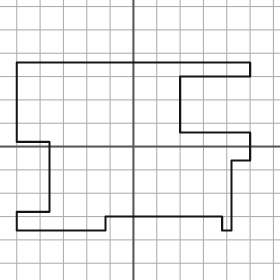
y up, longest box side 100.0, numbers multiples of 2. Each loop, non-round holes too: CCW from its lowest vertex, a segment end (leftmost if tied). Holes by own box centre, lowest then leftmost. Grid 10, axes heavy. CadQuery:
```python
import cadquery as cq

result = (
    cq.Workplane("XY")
    .moveTo(-50.0, -36.0)
    .lineTo(-12.0, -36.0)
    .lineTo(-12.0, -30.0)
    .lineTo(38.0, -30.0)
    .lineTo(38.0, -36.0)
    .lineTo(42.0, -36.0)
    .lineTo(42.0, -6.0)
    .lineTo(50.0, -6.0)
    .lineTo(50.0, 6.0)
    .lineTo(20.0, 6.0)
    .lineTo(20.0, 30.0)
    .lineTo(50.0, 30.0)
    .lineTo(50.0, 36.0)
    .lineTo(-50.0, 36.0)
    .lineTo(-50.0, 2.0)
    .lineTo(-36.0, 2.0)
    .lineTo(-36.0, -28.0)
    .lineTo(-50.0, -28.0)
    .close()
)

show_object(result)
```